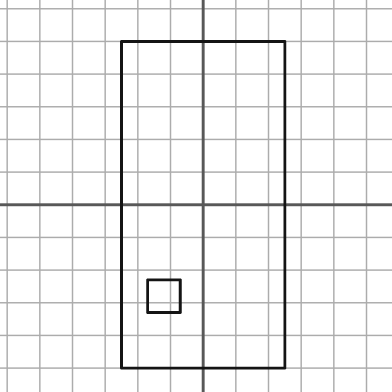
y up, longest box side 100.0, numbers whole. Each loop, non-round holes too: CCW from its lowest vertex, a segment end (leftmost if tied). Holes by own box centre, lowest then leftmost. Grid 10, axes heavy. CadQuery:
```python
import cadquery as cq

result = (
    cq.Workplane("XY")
    .moveTo(-25.0, -50.0)
    .lineTo(25.0, -50.0)
    .lineTo(25.0, 50.0)
    .lineTo(-25.0, 50.0)
    .close()
    .moveTo(-17.0, -33.0)
    .lineTo(-7.0, -33.0)
    .lineTo(-7.0, -23.0)
    .lineTo(-17.0, -23.0)
    .close()
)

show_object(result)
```